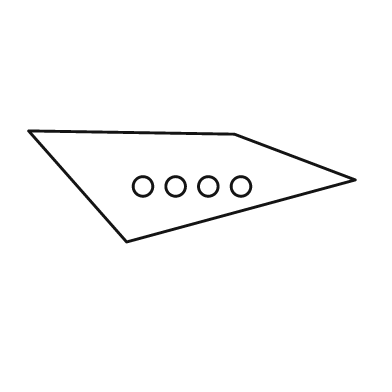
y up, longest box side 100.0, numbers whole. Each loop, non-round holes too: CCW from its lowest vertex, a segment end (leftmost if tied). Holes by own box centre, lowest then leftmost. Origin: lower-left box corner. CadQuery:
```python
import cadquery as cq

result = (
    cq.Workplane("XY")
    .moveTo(30.0, 0.0)
    .lineTo(100.0, 19.0)
    .lineTo(63.0, 33.0)
    .lineTo(0.0, 34.0)
    .close()
    .moveTo(35.0, 17.0)
    .circle(3.0)
    .moveTo(45.0, 17.0)
    .circle(3.0)
    .moveTo(55.0, 17.0)
    .circle(3.0)
    .moveTo(65.0, 17.0)
    .circle(3.0)
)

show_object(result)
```